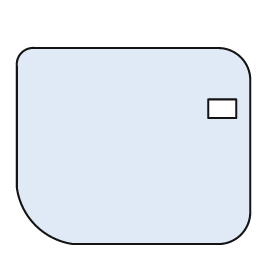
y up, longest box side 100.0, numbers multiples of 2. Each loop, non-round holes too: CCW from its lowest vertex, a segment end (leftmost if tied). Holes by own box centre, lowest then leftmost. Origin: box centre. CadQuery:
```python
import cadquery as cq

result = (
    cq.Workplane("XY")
    .moveTo(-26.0, -42.0)
    .lineTo(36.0, -42.0)
    .threePointArc((46.0, -38.0), (50.0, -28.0))
    .lineTo(50.0, 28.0)
    .threePointArc((46.0, 38.0), (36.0, 42.0))
    .lineTo(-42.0, 42.0)
    .threePointArc((-48.0, 40.0), (-50.0, 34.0))
    .lineTo(-50.0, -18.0)
    .threePointArc((-42.0, -34.0), (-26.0, -42.0))
    .close()
    .moveTo(32.0, 12.0)
    .lineTo(44.0, 12.0)
    .lineTo(44.0, 20.0)
    .lineTo(32.0, 20.0)
    .close()
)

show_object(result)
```